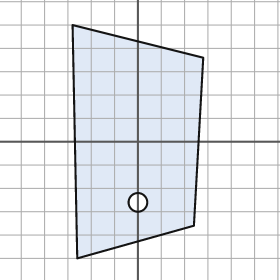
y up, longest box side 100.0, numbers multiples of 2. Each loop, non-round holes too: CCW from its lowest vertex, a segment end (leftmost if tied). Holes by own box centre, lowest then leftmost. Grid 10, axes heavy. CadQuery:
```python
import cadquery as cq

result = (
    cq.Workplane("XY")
    .moveTo(-26.0, -50.0)
    .lineTo(24.0, -36.0)
    .lineTo(28.0, 36.0)
    .lineTo(-28.0, 50.0)
    .close()
    .moveTo(0.0, -26.0)
    .circle(4.0)
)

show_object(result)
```